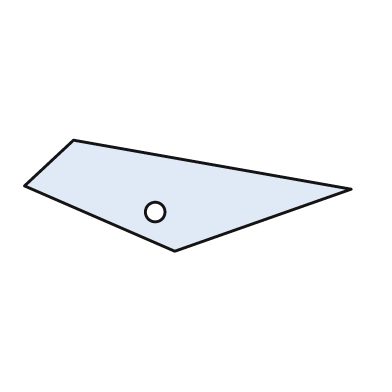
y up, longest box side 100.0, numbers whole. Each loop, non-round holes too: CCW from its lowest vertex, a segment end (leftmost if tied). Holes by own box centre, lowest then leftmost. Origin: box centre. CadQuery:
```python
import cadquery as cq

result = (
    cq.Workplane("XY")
    .moveTo(-4.0, -17.0)
    .lineTo(50.0, 2.0)
    .lineTo(-35.0, 17.0)
    .lineTo(-50.0, 3.0)
    .close()
    .moveTo(-10.0, -5.0)
    .circle(3.0)
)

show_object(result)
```